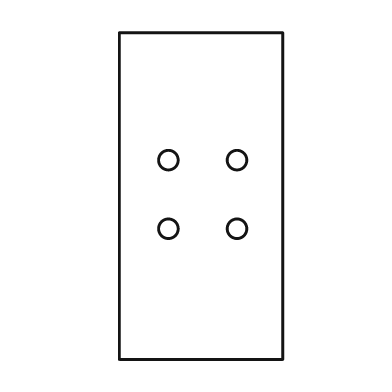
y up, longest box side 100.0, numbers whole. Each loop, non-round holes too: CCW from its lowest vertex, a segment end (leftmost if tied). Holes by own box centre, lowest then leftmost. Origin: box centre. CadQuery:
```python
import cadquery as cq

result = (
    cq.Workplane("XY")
    .moveTo(-25.0, -50.0)
    .lineTo(25.0, -50.0)
    .lineTo(25.0, 50.0)
    .lineTo(-25.0, 50.0)
    .close()
    .moveTo(-10.0, -10.0)
    .circle(3.0)
    .moveTo(11.0, -10.0)
    .circle(3.0)
    .moveTo(-10.0, 11.0)
    .circle(3.0)
    .moveTo(11.0, 11.0)
    .circle(3.0)
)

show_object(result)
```